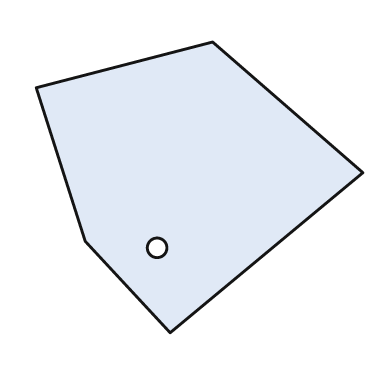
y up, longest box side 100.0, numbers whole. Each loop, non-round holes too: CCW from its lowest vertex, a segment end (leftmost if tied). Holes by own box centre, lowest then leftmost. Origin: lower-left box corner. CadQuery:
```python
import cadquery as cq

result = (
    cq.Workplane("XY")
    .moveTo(41.0, 0.0)
    .lineTo(100.0, 49.0)
    .lineTo(54.0, 89.0)
    .lineTo(0.0, 75.0)
    .lineTo(15.0, 28.0)
    .close()
    .moveTo(37.0, 26.0)
    .circle(3.0)
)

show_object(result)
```